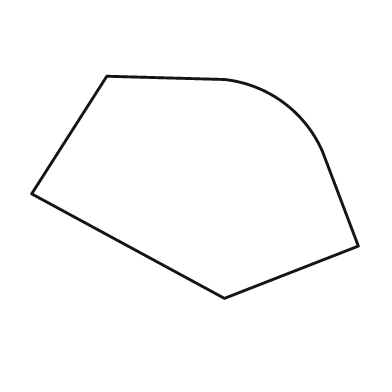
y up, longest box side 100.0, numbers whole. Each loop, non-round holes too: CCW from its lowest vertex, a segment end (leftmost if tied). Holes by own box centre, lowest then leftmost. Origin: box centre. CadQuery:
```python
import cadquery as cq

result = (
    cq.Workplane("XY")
    .moveTo(9.0, -34.0)
    .lineTo(50.0, -18.0)
    .lineTo(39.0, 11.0)
    .threePointArc((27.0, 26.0), (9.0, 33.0))
    .lineTo(-27.0, 34.0)
    .lineTo(-50.0, -2.0)
    .close()
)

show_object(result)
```